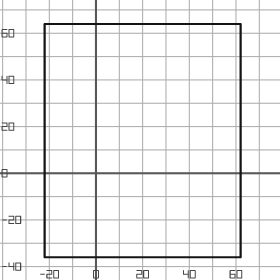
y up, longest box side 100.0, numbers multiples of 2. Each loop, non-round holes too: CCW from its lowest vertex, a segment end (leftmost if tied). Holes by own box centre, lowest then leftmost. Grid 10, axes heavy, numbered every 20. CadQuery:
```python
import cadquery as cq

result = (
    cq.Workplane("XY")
    .moveTo(-22.0, -36.0)
    .lineTo(62.0, -36.0)
    .lineTo(62.0, 64.0)
    .lineTo(-22.0, 64.0)
    .close()
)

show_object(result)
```